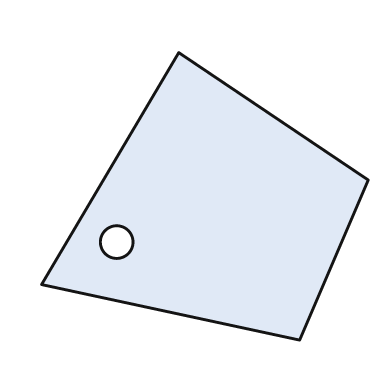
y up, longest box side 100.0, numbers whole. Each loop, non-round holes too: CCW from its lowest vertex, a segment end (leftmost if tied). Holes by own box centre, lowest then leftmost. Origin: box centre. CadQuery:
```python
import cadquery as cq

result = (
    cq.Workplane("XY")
    .moveTo(29.0, -44.0)
    .lineTo(50.0, 5.0)
    .lineTo(-8.0, 44.0)
    .lineTo(-50.0, -27.0)
    .close()
    .moveTo(-27.0, -14.0)
    .circle(5.0)
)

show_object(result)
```